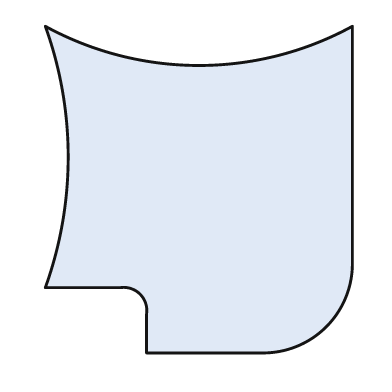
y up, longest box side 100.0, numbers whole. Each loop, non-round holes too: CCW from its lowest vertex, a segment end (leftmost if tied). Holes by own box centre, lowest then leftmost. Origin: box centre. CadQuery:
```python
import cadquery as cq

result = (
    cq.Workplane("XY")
    .moveTo(-16.0, -50.0)
    .lineTo(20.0, -50.0)
    .threePointArc((39.0, -42.0), (47.0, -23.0))
    .lineTo(47.0, 50.0)
    .threePointArc((0.0, 38.0), (-47.0, 50.0))
    .threePointArc((-40.0, 10.0), (-47.0, -30.0))
    .lineTo(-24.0, -30.0)
    .threePointArc((-18.0, -32.0), (-16.0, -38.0))
    .close()
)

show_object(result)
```